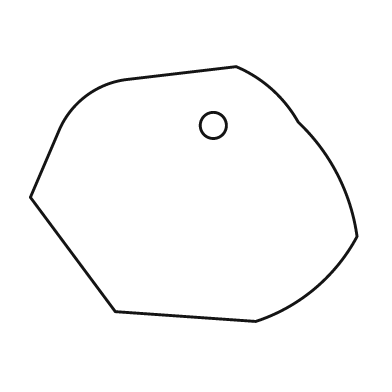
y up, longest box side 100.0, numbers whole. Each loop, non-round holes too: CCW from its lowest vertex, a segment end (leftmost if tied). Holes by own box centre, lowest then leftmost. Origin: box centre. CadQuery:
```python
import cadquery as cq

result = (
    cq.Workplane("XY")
    .moveTo(19.0, -39.0)
    .threePointArc((37.0, -29.0), (50.0, -13.0))
    .threePointArc((44.0, 6.0), (32.0, 22.0))
    .threePointArc((24.0, 32.0), (13.0, 39.0))
    .lineTo(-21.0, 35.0)
    .threePointArc((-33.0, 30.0), (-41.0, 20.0))
    .lineTo(-50.0, -1.0)
    .lineTo(-24.0, -36.0)
    .close()
    .moveTo(6.0, 21.0)
    .circle(4.0)
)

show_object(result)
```